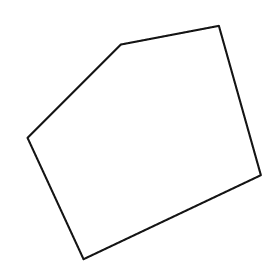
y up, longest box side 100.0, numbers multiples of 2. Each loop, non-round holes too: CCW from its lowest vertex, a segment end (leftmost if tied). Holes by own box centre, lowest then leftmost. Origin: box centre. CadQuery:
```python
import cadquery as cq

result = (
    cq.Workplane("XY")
    .moveTo(-26.0, -50.0)
    .lineTo(50.0, -14.0)
    .lineTo(32.0, 50.0)
    .lineTo(-10.0, 42.0)
    .lineTo(-50.0, 2.0)
    .close()
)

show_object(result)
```